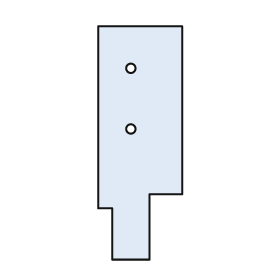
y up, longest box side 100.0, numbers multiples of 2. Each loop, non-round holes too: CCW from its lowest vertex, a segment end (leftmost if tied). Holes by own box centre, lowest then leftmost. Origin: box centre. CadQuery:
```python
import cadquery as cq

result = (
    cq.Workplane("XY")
    .moveTo(-12.0, -50.0)
    .lineTo(4.0, -50.0)
    .lineTo(4.0, -22.0)
    .lineTo(18.0, -22.0)
    .lineTo(18.0, 50.0)
    .lineTo(-18.0, 50.0)
    .lineTo(-18.0, -28.0)
    .lineTo(-12.0, -28.0)
    .close()
    .moveTo(-4.0, 6.0)
    .circle(2.0)
    .moveTo(-4.0, 32.0)
    .circle(2.0)
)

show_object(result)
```